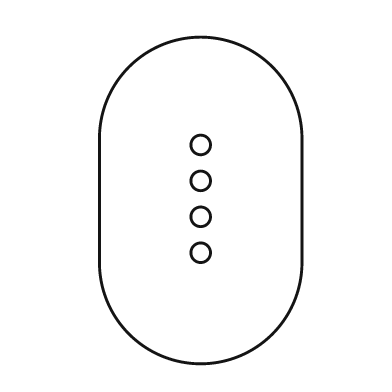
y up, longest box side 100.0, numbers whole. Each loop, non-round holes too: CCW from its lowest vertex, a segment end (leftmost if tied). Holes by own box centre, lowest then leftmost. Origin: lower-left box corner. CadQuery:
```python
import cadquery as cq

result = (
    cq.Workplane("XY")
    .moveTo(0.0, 31.0)
    .threePointArc((31.0, 0.0), (62.0, 31.0))
    .lineTo(62.0, 69.0)
    .threePointArc((31.0, 100.0), (0.0, 69.0))
    .close()
    .moveTo(31.0, 34.0)
    .circle(3.0)
    .moveTo(31.0, 45.0)
    .circle(3.0)
    .moveTo(31.0, 56.0)
    .circle(3.0)
    .moveTo(31.0, 67.0)
    .circle(3.0)
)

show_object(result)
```